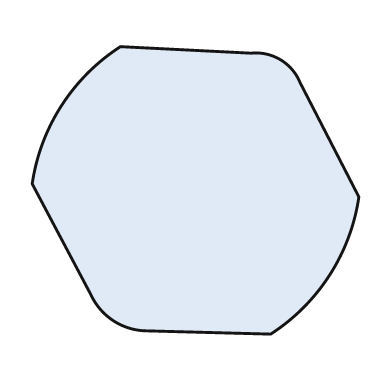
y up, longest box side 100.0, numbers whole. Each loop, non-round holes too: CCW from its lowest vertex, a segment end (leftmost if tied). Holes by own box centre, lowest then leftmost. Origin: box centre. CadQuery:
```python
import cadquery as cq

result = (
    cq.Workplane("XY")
    .moveTo(23.0, -44.0)
    .threePointArc((41.0, -26.0), (50.0, -2.0))
    .lineTo(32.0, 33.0)
    .threePointArc((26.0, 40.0), (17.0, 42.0))
    .lineTo(-23.0, 44.0)
    .threePointArc((-41.0, 26.0), (-50.0, 2.0))
    .lineTo(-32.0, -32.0)
    .threePointArc((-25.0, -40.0), (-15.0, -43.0))
    .close()
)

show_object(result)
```